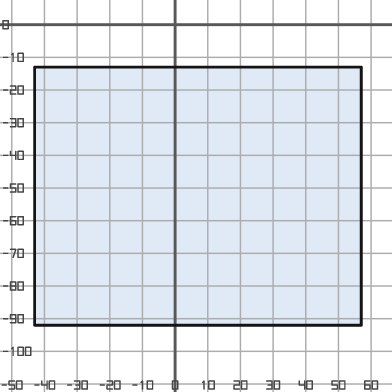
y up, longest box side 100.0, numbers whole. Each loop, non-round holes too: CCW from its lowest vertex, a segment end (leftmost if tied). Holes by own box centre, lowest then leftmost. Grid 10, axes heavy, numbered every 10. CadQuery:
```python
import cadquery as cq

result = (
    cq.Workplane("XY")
    .moveTo(-43.0, -92.0)
    .lineTo(57.0, -92.0)
    .lineTo(57.0, -13.0)
    .lineTo(-43.0, -13.0)
    .close()
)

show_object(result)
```